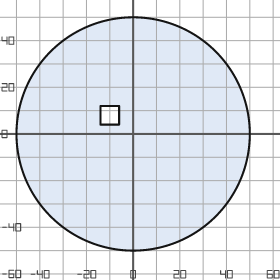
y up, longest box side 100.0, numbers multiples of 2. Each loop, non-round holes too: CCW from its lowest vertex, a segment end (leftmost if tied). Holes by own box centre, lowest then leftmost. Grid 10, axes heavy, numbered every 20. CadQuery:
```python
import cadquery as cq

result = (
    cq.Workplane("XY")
    .moveTo(0.0, 0.0)
    .circle(50.0)
    .moveTo(-14.0, 4.0)
    .lineTo(-6.0, 4.0)
    .lineTo(-6.0, 12.0)
    .lineTo(-14.0, 12.0)
    .close()
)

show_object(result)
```